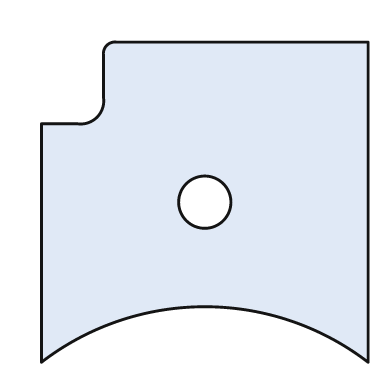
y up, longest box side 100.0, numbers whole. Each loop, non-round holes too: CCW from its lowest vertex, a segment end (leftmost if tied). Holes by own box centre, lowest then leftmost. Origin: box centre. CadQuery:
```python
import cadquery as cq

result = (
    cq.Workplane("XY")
    .moveTo(-50.0, -49.0)
    .threePointArc((0.0, -32.0), (50.0, -49.0))
    .lineTo(50.0, 49.0)
    .lineTo(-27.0, 49.0)
    .threePointArc((-30.0, 48.0), (-31.0, 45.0))
    .lineTo(-31.0, 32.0)
    .threePointArc((-33.0, 26.0), (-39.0, 24.0))
    .lineTo(-50.0, 24.0)
    .close()
    .moveTo(0.0, 0.0)
    .circle(8.0)
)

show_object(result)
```